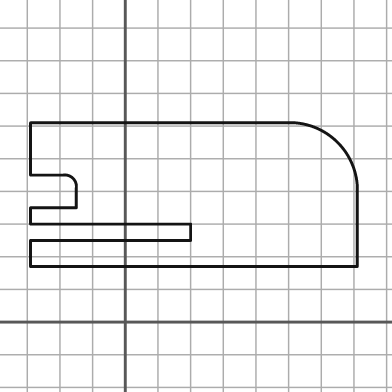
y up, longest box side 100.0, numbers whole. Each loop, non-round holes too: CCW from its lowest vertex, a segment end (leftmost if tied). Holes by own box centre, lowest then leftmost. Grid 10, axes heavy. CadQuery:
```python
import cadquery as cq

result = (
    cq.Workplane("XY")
    .moveTo(-29.0, 17.0)
    .lineTo(71.0, 17.0)
    .lineTo(71.0, 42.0)
    .threePointArc((65.0, 55.0), (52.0, 61.0))
    .lineTo(-29.0, 61.0)
    .lineTo(-29.0, 45.0)
    .lineTo(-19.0, 45.0)
    .threePointArc((-16.0, 44.0), (-15.0, 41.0))
    .lineTo(-15.0, 35.0)
    .lineTo(-29.0, 35.0)
    .lineTo(-29.0, 30.0)
    .lineTo(20.0, 30.0)
    .lineTo(20.0, 25.0)
    .lineTo(-29.0, 25.0)
    .close()
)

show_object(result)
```